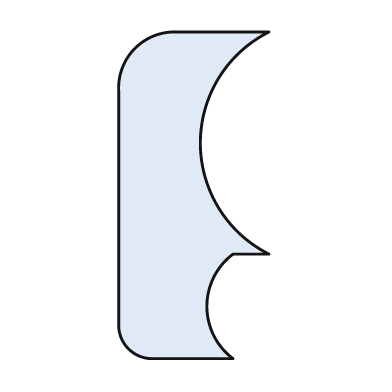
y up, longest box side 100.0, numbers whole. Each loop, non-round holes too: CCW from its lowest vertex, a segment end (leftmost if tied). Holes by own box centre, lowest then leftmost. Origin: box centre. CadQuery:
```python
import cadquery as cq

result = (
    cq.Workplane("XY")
    .moveTo(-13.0, -50.0)
    .lineTo(12.0, -50.0)
    .threePointArc((4.0, -34.0), (12.0, -18.0))
    .lineTo(23.0, -18.0)
    .threePointArc((2.0, 16.0), (23.0, 50.0))
    .lineTo(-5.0, 50.0)
    .threePointArc((-18.0, 45.0), (-23.0, 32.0))
    .lineTo(-23.0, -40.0)
    .threePointArc((-20.0, -47.0), (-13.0, -50.0))
    .close()
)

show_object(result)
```